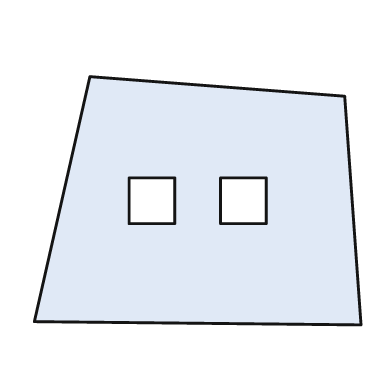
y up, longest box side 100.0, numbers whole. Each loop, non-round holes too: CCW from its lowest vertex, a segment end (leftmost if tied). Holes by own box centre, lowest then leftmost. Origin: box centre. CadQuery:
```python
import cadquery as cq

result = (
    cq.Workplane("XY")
    .moveTo(50.0, -38.0)
    .lineTo(45.0, 32.0)
    .lineTo(-33.0, 38.0)
    .lineTo(-50.0, -37.0)
    .close()
    .moveTo(-21.0, -7.0)
    .lineTo(-7.0, -7.0)
    .lineTo(-7.0, 7.0)
    .lineTo(-21.0, 7.0)
    .close()
    .moveTo(7.0, -7.0)
    .lineTo(21.0, -7.0)
    .lineTo(21.0, 7.0)
    .lineTo(7.0, 7.0)
    .close()
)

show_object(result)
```